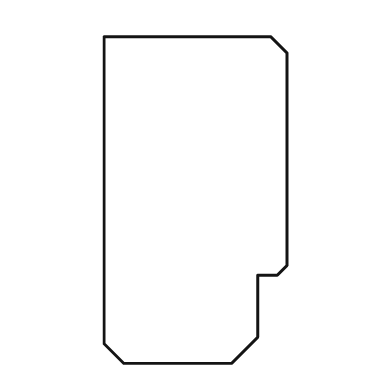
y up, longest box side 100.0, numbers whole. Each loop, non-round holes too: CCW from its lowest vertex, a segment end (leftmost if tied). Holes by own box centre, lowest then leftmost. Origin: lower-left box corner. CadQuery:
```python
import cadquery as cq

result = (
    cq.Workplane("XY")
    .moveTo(6.0, 0.0)
    .lineTo(39.0, 0.0)
    .lineTo(47.0, 8.0)
    .lineTo(47.0, 27.0)
    .lineTo(53.0, 27.0)
    .lineTo(56.0, 30.0)
    .lineTo(56.0, 95.0)
    .lineTo(51.0, 100.0)
    .lineTo(0.0, 100.0)
    .lineTo(0.0, 6.0)
    .close()
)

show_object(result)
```